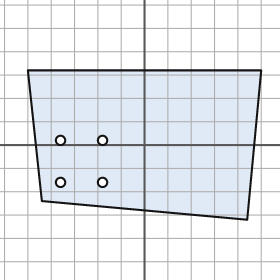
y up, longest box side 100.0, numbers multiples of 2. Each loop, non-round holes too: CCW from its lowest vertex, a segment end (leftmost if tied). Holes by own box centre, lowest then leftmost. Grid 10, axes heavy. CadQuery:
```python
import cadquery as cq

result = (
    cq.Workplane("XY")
    .moveTo(44.0, -32.0)
    .lineTo(50.0, 32.0)
    .lineTo(-50.0, 32.0)
    .lineTo(-44.0, -24.0)
    .close()
    .moveTo(-36.0, -16.0)
    .circle(2.0)
    .moveTo(-18.0, -16.0)
    .circle(2.0)
    .moveTo(-36.0, 2.0)
    .circle(2.0)
    .moveTo(-18.0, 2.0)
    .circle(2.0)
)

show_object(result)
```